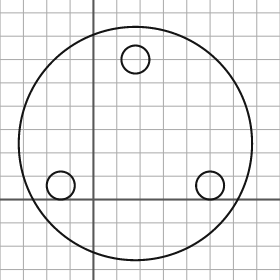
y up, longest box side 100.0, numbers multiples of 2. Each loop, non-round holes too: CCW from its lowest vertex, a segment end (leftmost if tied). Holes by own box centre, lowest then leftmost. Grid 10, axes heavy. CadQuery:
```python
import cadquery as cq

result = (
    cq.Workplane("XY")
    .moveTo(18.0, 24.0)
    .circle(50.0)
    .moveTo(-14.0, 6.0)
    .circle(6.0)
    .moveTo(50.0, 6.0)
    .circle(6.0)
    .moveTo(18.0, 60.0)
    .circle(6.0)
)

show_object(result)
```